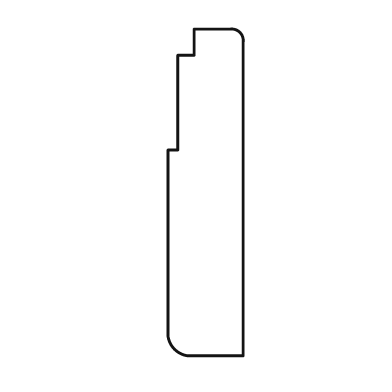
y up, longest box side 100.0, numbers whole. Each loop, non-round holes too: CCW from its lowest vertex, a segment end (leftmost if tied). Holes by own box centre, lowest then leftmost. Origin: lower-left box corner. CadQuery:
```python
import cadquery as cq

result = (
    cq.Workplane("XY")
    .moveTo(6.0, 0.0)
    .lineTo(23.0, 0.0)
    .lineTo(23.0, 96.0)
    .threePointArc((22.0, 99.0), (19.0, 100.0))
    .lineTo(8.0, 100.0)
    .lineTo(8.0, 92.0)
    .lineTo(3.0, 92.0)
    .lineTo(3.0, 63.0)
    .lineTo(0.0, 63.0)
    .lineTo(0.0, 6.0)
    .threePointArc((2.0, 2.0), (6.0, 0.0))
    .close()
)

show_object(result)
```